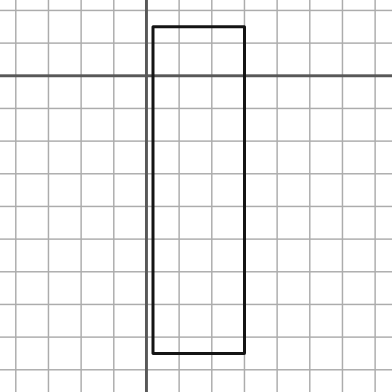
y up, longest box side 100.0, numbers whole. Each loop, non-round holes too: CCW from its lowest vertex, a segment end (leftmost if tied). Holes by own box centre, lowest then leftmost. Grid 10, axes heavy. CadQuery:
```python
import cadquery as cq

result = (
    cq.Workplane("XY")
    .moveTo(2.0, -85.0)
    .lineTo(30.0, -85.0)
    .lineTo(30.0, 15.0)
    .lineTo(2.0, 15.0)
    .close()
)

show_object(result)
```